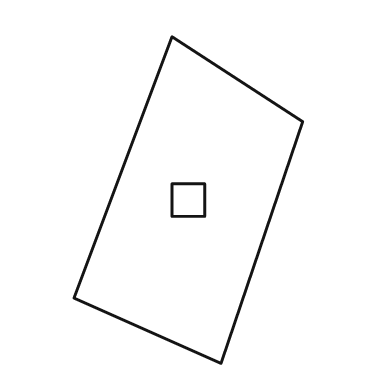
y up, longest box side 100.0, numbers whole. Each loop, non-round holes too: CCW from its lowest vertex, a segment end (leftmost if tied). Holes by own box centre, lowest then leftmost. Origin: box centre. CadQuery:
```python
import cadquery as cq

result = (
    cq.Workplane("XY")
    .moveTo(10.0, -50.0)
    .lineTo(35.0, 24.0)
    .lineTo(-5.0, 50.0)
    .lineTo(-35.0, -30.0)
    .close()
    .moveTo(-5.0, -5.0)
    .lineTo(5.0, -5.0)
    .lineTo(5.0, 5.0)
    .lineTo(-5.0, 5.0)
    .close()
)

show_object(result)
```